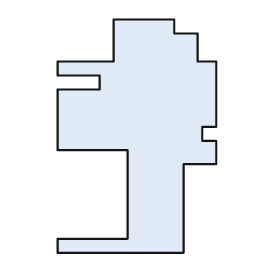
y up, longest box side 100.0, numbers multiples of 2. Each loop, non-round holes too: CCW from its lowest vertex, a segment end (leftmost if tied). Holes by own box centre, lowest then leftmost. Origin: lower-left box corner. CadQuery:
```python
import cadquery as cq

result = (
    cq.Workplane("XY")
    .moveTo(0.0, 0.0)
    .lineTo(54.0, 0.0)
    .lineTo(54.0, 38.0)
    .lineTo(68.0, 38.0)
    .lineTo(68.0, 48.0)
    .lineTo(62.0, 48.0)
    .lineTo(62.0, 54.0)
    .lineTo(68.0, 54.0)
    .lineTo(68.0, 82.0)
    .lineTo(60.0, 82.0)
    .lineTo(60.0, 94.0)
    .lineTo(50.0, 94.0)
    .lineTo(50.0, 100.0)
    .lineTo(24.0, 100.0)
    .lineTo(24.0, 82.0)
    .lineTo(0.0, 82.0)
    .lineTo(0.0, 76.0)
    .lineTo(18.0, 76.0)
    .lineTo(18.0, 70.0)
    .lineTo(0.0, 70.0)
    .lineTo(0.0, 44.0)
    .lineTo(30.0, 44.0)
    .lineTo(30.0, 6.0)
    .lineTo(0.0, 6.0)
    .close()
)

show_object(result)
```